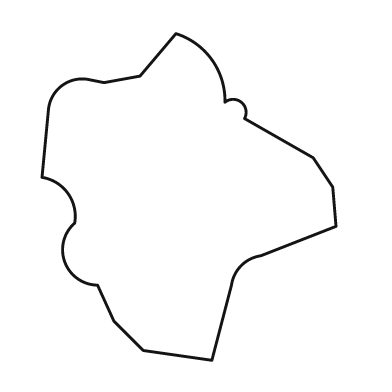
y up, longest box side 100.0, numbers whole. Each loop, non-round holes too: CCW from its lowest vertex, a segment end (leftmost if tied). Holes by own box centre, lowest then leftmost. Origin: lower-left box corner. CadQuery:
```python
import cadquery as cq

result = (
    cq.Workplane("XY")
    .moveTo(52.0, 0.0)
    .lineTo(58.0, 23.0)
    .threePointArc((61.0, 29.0), (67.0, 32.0))
    .lineTo(90.0, 41.0)
    .lineTo(89.0, 53.0)
    .lineTo(83.0, 62.0)
    .lineTo(62.0, 74.0)
    .threePointArc((61.0, 79.0), (56.0, 79.0))
    .threePointArc((52.0, 92.0), (41.0, 100.0))
    .lineTo(30.0, 87.0)
    .lineTo(19.0, 85.0)
    .lineTo(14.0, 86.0)
    .threePointArc((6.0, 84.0), (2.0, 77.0))
    .lineTo(0.0, 56.0)
    .threePointArc((8.0, 51.0), (10.0, 42.0))
    .threePointArc((7.0, 30.0), (17.0, 23.0))
    .lineTo(22.0, 12.0)
    .lineTo(31.0, 3.0)
    .close()
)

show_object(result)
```